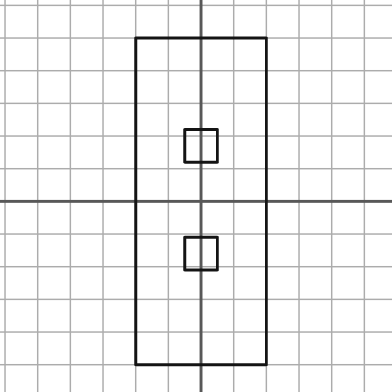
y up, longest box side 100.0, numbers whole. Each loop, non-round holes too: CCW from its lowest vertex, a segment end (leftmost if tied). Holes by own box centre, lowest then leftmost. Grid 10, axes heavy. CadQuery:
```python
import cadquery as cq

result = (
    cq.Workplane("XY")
    .moveTo(-20.0, -50.0)
    .lineTo(20.0, -50.0)
    .lineTo(20.0, 50.0)
    .lineTo(-20.0, 50.0)
    .close()
    .moveTo(-5.0, -21.0)
    .lineTo(5.0, -21.0)
    .lineTo(5.0, -11.0)
    .lineTo(-5.0, -11.0)
    .close()
    .moveTo(-5.0, 12.0)
    .lineTo(5.0, 12.0)
    .lineTo(5.0, 22.0)
    .lineTo(-5.0, 22.0)
    .close()
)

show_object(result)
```